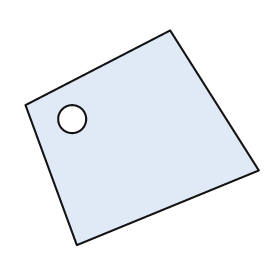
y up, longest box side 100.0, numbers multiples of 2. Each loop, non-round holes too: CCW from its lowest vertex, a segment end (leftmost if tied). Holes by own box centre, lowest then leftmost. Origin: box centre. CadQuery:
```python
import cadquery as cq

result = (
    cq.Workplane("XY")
    .moveTo(-28.0, -46.0)
    .lineTo(50.0, -14.0)
    .lineTo(12.0, 46.0)
    .lineTo(-50.0, 14.0)
    .close()
    .moveTo(-30.0, 8.0)
    .circle(6.0)
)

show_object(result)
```